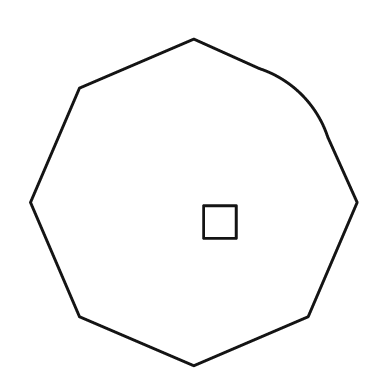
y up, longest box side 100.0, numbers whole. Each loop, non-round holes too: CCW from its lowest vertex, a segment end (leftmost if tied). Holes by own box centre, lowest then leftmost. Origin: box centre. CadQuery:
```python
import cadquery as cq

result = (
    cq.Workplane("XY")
    .moveTo(0.0, -50.0)
    .lineTo(35.0, -35.0)
    .lineTo(50.0, 0.0)
    .lineTo(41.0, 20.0)
    .threePointArc((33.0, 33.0), (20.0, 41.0))
    .lineTo(0.0, 50.0)
    .lineTo(-35.0, 35.0)
    .lineTo(-50.0, 0.0)
    .lineTo(-35.0, -35.0)
    .close()
    .moveTo(3.0, -11.0)
    .lineTo(13.0, -11.0)
    .lineTo(13.0, -1.0)
    .lineTo(3.0, -1.0)
    .close()
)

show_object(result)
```